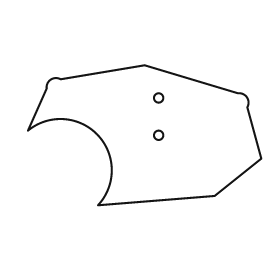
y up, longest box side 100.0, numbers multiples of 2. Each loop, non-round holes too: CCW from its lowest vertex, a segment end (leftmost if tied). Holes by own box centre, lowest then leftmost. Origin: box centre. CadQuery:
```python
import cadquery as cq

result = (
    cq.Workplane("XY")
    .moveTo(-20.0, -30.0)
    .lineTo(30.0, -26.0)
    .lineTo(50.0, -10.0)
    .lineTo(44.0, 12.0)
    .threePointArc((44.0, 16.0), (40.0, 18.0))
    .lineTo(0.0, 30.0)
    .lineTo(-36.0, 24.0)
    .threePointArc((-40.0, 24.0), (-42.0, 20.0))
    .lineTo(-50.0, 2.0)
    .threePointArc((-20.0, 0.0), (-20.0, -30.0))
    .close()
    .moveTo(6.0, 0.0)
    .circle(2.0)
    .moveTo(6.0, 16.0)
    .circle(2.0)
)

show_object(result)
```